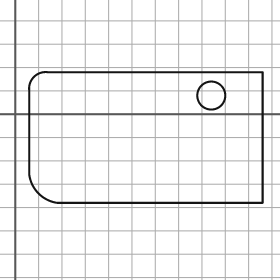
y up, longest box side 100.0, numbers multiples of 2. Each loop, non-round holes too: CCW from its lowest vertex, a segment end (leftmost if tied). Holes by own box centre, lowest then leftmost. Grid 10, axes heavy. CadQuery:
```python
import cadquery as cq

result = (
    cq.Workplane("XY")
    .moveTo(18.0, -38.0)
    .lineTo(106.0, -38.0)
    .lineTo(106.0, 18.0)
    .lineTo(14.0, 18.0)
    .threePointArc((8.0, 16.0), (6.0, 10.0))
    .lineTo(6.0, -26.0)
    .threePointArc((10.0, -34.0), (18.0, -38.0))
    .close()
    .moveTo(84.0, 8.0)
    .circle(6.0)
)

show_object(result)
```